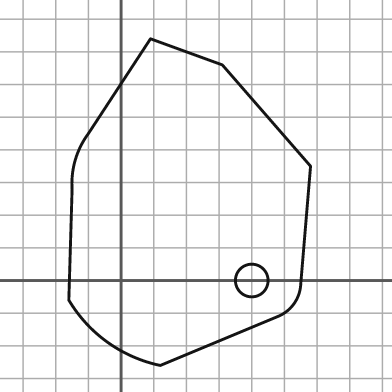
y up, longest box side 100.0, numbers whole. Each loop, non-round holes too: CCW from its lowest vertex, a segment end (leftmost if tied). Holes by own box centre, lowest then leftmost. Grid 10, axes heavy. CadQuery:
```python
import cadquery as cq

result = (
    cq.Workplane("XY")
    .moveTo(12.0, -26.0)
    .lineTo(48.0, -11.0)
    .threePointArc((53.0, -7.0), (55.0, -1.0))
    .lineTo(58.0, 35.0)
    .lineTo(31.0, 66.0)
    .lineTo(9.0, 74.0)
    .lineTo(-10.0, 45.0)
    .threePointArc((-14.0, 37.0), (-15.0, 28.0))
    .lineTo(-16.0, -6.0)
    .threePointArc((-4.0, -19.0), (12.0, -26.0))
    .close()
    .moveTo(40.0, 0.0)
    .circle(5.0)
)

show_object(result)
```